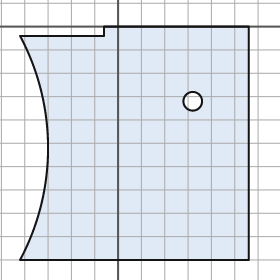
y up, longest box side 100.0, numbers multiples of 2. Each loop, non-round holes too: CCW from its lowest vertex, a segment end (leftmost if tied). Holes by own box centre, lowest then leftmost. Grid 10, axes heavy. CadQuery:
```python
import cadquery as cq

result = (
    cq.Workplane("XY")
    .moveTo(-42.0, -100.0)
    .lineTo(56.0, -100.0)
    .lineTo(56.0, 0.0)
    .lineTo(-6.0, 0.0)
    .lineTo(-6.0, -4.0)
    .lineTo(-42.0, -4.0)
    .threePointArc((-30.0, -52.0), (-42.0, -100.0))
    .close()
    .moveTo(32.0, -32.0)
    .circle(4.0)
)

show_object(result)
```